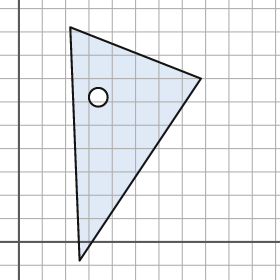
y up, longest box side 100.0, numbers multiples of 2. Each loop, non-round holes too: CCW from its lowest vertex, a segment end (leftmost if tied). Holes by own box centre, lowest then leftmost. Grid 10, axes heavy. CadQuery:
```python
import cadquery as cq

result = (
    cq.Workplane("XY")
    .moveTo(26.0, -8.0)
    .lineTo(78.0, 70.0)
    .lineTo(22.0, 92.0)
    .close()
    .moveTo(34.0, 62.0)
    .circle(4.0)
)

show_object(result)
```